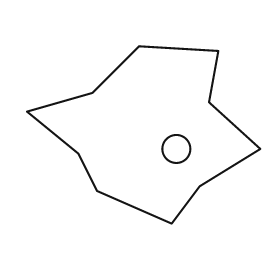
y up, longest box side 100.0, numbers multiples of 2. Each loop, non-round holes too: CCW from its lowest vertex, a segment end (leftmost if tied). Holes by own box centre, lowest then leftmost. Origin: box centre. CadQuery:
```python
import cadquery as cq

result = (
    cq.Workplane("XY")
    .moveTo(12.0, -38.0)
    .lineTo(24.0, -22.0)
    .lineTo(50.0, -6.0)
    .lineTo(28.0, 14.0)
    .lineTo(32.0, 36.0)
    .lineTo(-2.0, 38.0)
    .lineTo(-22.0, 18.0)
    .lineTo(-50.0, 10.0)
    .lineTo(-28.0, -8.0)
    .lineTo(-20.0, -24.0)
    .close()
    .moveTo(14.0, -6.0)
    .circle(6.0)
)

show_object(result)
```